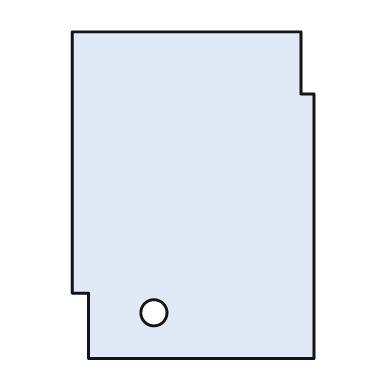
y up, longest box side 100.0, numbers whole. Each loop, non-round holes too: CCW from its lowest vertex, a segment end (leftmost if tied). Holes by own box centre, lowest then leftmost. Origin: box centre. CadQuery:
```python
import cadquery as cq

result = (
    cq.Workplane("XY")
    .moveTo(-32.0, -50.0)
    .lineTo(37.0, -50.0)
    .lineTo(37.0, 31.0)
    .lineTo(33.0, 31.0)
    .lineTo(33.0, 50.0)
    .lineTo(-37.0, 50.0)
    .lineTo(-37.0, -30.0)
    .lineTo(-32.0, -30.0)
    .close()
    .moveTo(-12.0, -36.0)
    .circle(4.0)
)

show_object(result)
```